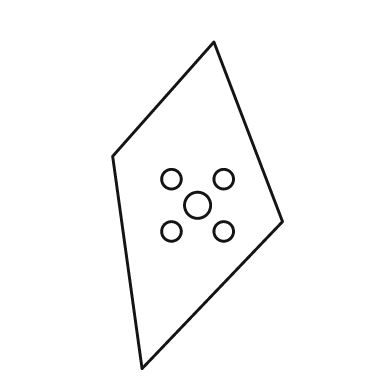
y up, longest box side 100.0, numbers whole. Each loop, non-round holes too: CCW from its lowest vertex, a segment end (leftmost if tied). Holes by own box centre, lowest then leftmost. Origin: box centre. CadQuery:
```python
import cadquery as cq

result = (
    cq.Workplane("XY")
    .moveTo(-17.0, -50.0)
    .lineTo(26.0, -5.0)
    .lineTo(5.0, 50.0)
    .lineTo(-26.0, 15.0)
    .close()
    .moveTo(-8.0, -8.0)
    .circle(3.0)
    .moveTo(8.0, -8.0)
    .circle(3.0)
    .moveTo(0.0, 0.0)
    .circle(4.0)
    .moveTo(-8.0, 8.0)
    .circle(3.0)
    .moveTo(8.0, 8.0)
    .circle(3.0)
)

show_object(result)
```